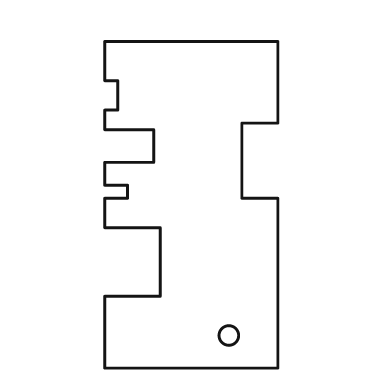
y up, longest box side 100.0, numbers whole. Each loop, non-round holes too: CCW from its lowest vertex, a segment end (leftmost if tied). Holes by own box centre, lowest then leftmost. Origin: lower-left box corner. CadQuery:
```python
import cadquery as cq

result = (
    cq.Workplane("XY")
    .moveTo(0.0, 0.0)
    .lineTo(53.0, 0.0)
    .lineTo(53.0, 52.0)
    .lineTo(42.0, 52.0)
    .lineTo(42.0, 75.0)
    .lineTo(53.0, 75.0)
    .lineTo(53.0, 100.0)
    .lineTo(0.0, 100.0)
    .lineTo(0.0, 88.0)
    .lineTo(4.0, 88.0)
    .lineTo(4.0, 79.0)
    .lineTo(0.0, 79.0)
    .lineTo(0.0, 73.0)
    .lineTo(15.0, 73.0)
    .lineTo(15.0, 63.0)
    .lineTo(0.0, 63.0)
    .lineTo(0.0, 56.0)
    .lineTo(7.0, 56.0)
    .lineTo(7.0, 52.0)
    .lineTo(0.0, 52.0)
    .lineTo(0.0, 43.0)
    .lineTo(17.0, 43.0)
    .lineTo(17.0, 22.0)
    .lineTo(0.0, 22.0)
    .close()
    .moveTo(38.0, 10.0)
    .circle(3.0)
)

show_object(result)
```